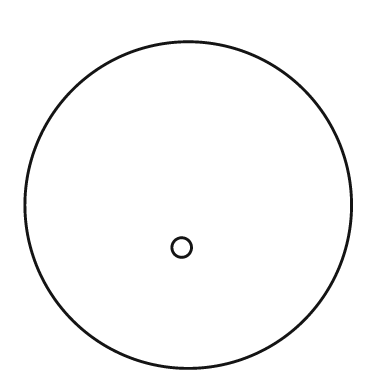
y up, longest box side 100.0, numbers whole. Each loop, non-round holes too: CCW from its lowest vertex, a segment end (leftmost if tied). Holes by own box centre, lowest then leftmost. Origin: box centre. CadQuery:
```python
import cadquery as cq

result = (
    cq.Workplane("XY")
    .moveTo(0.0, 0.0)
    .circle(50.0)
    .moveTo(-2.0, -13.0)
    .circle(3.0)
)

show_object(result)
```